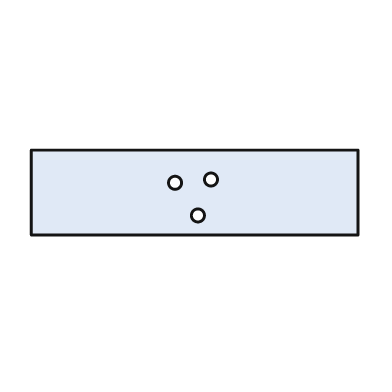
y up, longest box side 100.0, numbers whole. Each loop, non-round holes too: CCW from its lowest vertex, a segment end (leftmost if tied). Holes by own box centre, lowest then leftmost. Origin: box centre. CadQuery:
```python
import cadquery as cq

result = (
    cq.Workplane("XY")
    .moveTo(-50.0, -13.0)
    .lineTo(50.0, -13.0)
    .lineTo(50.0, 13.0)
    .lineTo(-50.0, 13.0)
    .close()
    .moveTo(1.0, -7.0)
    .circle(2.0)
    .moveTo(-6.0, 3.0)
    .circle(2.0)
    .moveTo(5.0, 4.0)
    .circle(2.0)
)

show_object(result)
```